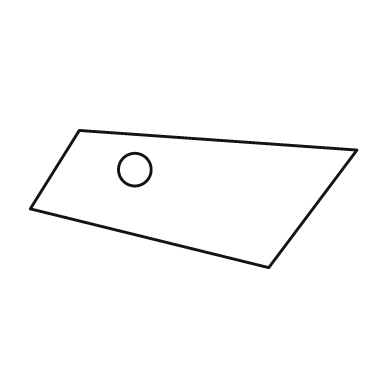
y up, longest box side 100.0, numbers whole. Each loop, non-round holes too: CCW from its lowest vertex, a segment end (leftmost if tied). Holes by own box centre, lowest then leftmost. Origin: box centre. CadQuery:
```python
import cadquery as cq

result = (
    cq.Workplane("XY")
    .moveTo(23.0, -21.0)
    .lineTo(50.0, 15.0)
    .lineTo(-35.0, 21.0)
    .lineTo(-50.0, -3.0)
    .close()
    .moveTo(-18.0, 9.0)
    .circle(5.0)
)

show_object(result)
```